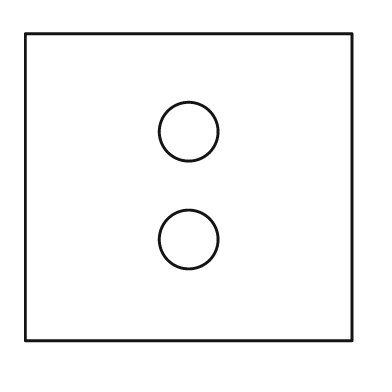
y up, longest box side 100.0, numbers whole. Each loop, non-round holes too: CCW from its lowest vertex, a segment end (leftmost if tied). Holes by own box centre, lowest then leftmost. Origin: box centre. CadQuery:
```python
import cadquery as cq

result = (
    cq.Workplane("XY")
    .moveTo(-50.0, -47.0)
    .lineTo(50.0, -47.0)
    .lineTo(50.0, 47.0)
    .lineTo(-50.0, 47.0)
    .close()
    .moveTo(0.0, -16.0)
    .circle(9.0)
    .moveTo(0.0, 17.0)
    .circle(9.0)
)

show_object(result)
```